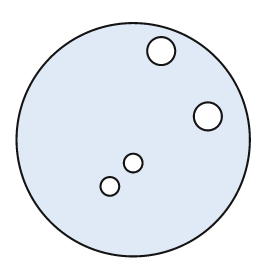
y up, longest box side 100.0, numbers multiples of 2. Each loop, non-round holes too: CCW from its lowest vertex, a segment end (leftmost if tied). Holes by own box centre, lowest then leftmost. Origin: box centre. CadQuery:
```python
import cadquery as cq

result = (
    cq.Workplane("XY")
    .moveTo(0.0, 0.0)
    .circle(50.0)
    .moveTo(-10.0, -20.0)
    .circle(4.0)
    .moveTo(0.0, -10.0)
    .circle(4.0)
    .moveTo(32.0, 10.0)
    .circle(6.0)
    .moveTo(12.0, 38.0)
    .circle(6.0)
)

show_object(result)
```